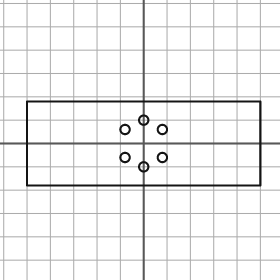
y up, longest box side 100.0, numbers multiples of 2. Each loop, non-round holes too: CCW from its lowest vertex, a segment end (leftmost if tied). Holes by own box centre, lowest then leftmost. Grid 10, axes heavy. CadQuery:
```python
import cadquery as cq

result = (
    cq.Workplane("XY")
    .moveTo(-50.0, -18.0)
    .lineTo(50.0, -18.0)
    .lineTo(50.0, 18.0)
    .lineTo(-50.0, 18.0)
    .close()
    .moveTo(0.0, -10.0)
    .circle(2.0)
    .moveTo(-8.0, -6.0)
    .circle(2.0)
    .moveTo(8.0, -6.0)
    .circle(2.0)
    .moveTo(-8.0, 6.0)
    .circle(2.0)
    .moveTo(8.0, 6.0)
    .circle(2.0)
    .moveTo(0.0, 10.0)
    .circle(2.0)
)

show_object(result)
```